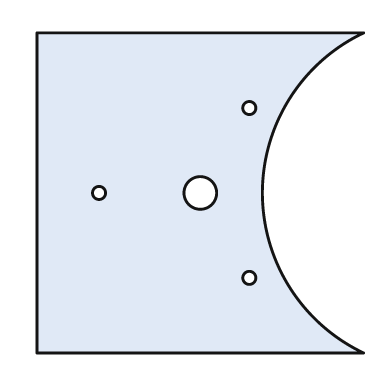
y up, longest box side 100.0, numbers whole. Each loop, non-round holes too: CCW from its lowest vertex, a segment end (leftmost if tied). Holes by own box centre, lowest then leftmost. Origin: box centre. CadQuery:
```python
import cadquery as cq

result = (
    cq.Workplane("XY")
    .moveTo(-50.0, -49.0)
    .lineTo(50.0, -49.0)
    .threePointArc((19.0, 0.0), (50.0, 49.0))
    .lineTo(-50.0, 49.0)
    .close()
    .moveTo(15.0, -26.0)
    .circle(2.0)
    .moveTo(-31.0, 0.0)
    .circle(2.0)
    .moveTo(0.0, 0.0)
    .circle(5.0)
    .moveTo(15.0, 26.0)
    .circle(2.0)
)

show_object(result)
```